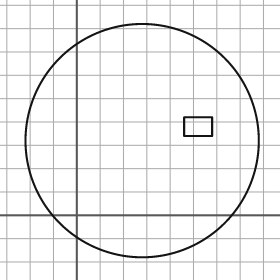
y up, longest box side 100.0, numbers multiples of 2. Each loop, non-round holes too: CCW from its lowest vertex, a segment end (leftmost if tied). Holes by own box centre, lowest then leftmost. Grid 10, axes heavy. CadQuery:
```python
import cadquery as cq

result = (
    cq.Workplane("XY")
    .moveTo(28.0, 32.0)
    .circle(50.0)
    .moveTo(46.0, 34.0)
    .lineTo(58.0, 34.0)
    .lineTo(58.0, 42.0)
    .lineTo(46.0, 42.0)
    .close()
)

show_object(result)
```